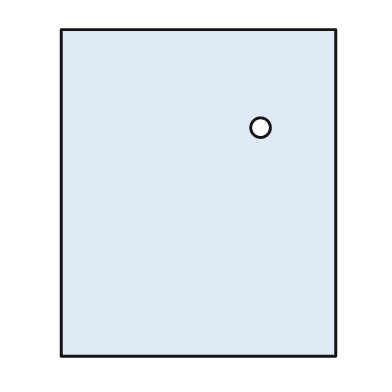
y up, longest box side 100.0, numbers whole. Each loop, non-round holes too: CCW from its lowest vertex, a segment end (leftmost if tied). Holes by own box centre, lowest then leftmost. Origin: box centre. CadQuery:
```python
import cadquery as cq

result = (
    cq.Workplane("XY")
    .moveTo(-42.0, -50.0)
    .lineTo(42.0, -50.0)
    .lineTo(42.0, 50.0)
    .lineTo(-42.0, 50.0)
    .close()
    .moveTo(19.0, 20.0)
    .circle(3.0)
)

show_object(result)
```